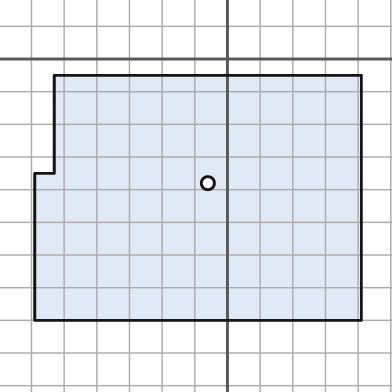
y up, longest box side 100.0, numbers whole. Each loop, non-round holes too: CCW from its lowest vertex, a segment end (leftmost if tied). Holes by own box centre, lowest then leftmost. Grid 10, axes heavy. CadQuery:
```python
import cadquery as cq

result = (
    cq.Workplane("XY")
    .moveTo(-59.0, -80.0)
    .lineTo(41.0, -80.0)
    .lineTo(41.0, -5.0)
    .lineTo(-53.0, -5.0)
    .lineTo(-53.0, -35.0)
    .lineTo(-59.0, -35.0)
    .close()
    .moveTo(-6.0, -38.0)
    .circle(2.0)
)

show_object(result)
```